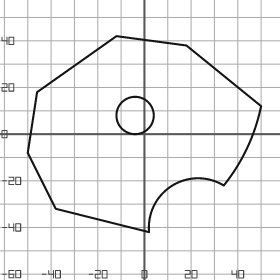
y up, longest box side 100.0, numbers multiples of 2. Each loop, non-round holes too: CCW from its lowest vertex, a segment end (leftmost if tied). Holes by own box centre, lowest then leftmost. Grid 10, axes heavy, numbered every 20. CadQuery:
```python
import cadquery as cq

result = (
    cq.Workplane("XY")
    .moveTo(2.0, -42.0)
    .threePointArc((12.0, -22.0), (34.0, -22.0))
    .threePointArc((44.0, -6.0), (50.0, 12.0))
    .lineTo(18.0, 38.0)
    .lineTo(-12.0, 42.0)
    .lineTo(-46.0, 18.0)
    .lineTo(-50.0, -8.0)
    .lineTo(-38.0, -32.0)
    .close()
    .moveTo(-4.0, 8.0)
    .circle(8.0)
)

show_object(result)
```